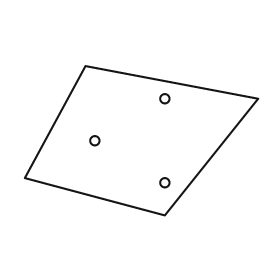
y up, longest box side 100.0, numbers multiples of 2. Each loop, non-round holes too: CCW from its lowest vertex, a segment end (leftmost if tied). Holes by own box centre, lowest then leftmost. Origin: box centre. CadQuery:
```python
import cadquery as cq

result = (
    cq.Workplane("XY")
    .moveTo(10.0, -32.0)
    .lineTo(50.0, 18.0)
    .lineTo(-24.0, 32.0)
    .lineTo(-50.0, -16.0)
    .close()
    .moveTo(10.0, -18.0)
    .circle(2.0)
    .moveTo(-20.0, 0.0)
    .circle(2.0)
    .moveTo(10.0, 18.0)
    .circle(2.0)
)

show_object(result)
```